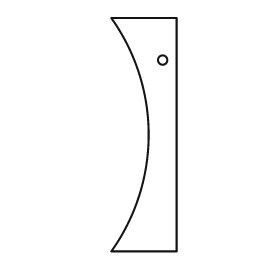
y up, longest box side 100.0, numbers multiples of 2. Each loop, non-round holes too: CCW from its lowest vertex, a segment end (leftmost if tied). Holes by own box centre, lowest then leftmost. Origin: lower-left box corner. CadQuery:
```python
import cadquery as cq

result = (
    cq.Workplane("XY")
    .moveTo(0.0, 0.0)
    .lineTo(28.0, 0.0)
    .lineTo(28.0, 100.0)
    .lineTo(0.0, 100.0)
    .threePointArc((16.0, 50.0), (0.0, 0.0))
    .close()
    .moveTo(22.0, 82.0)
    .circle(2.0)
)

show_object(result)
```